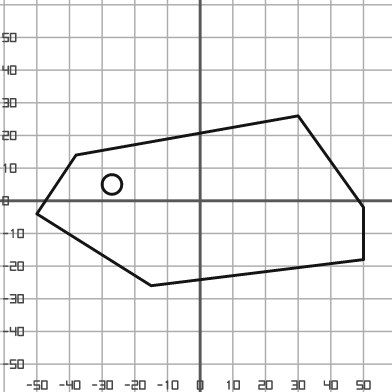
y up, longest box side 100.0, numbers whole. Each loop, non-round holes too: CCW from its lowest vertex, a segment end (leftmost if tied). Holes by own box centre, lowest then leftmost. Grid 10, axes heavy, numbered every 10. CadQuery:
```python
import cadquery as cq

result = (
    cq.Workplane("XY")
    .moveTo(-15.0, -26.0)
    .lineTo(50.0, -18.0)
    .lineTo(50.0, -2.0)
    .lineTo(30.0, 26.0)
    .lineTo(-38.0, 14.0)
    .lineTo(-50.0, -4.0)
    .close()
    .moveTo(-27.0, 5.0)
    .circle(3.0)
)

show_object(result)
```